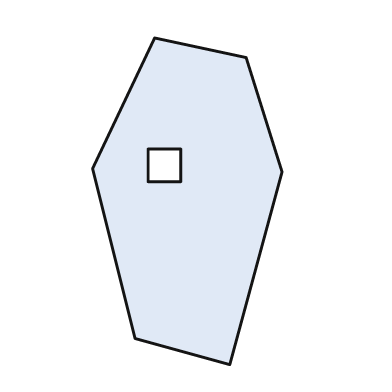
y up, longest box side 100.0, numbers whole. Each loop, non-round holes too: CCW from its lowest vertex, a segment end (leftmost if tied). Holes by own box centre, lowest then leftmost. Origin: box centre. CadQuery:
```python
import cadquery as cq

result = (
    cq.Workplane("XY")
    .moveTo(13.0, -50.0)
    .lineTo(29.0, 9.0)
    .lineTo(18.0, 44.0)
    .lineTo(-10.0, 50.0)
    .lineTo(-29.0, 10.0)
    .lineTo(-16.0, -42.0)
    .close()
    .moveTo(-12.0, 6.0)
    .lineTo(-2.0, 6.0)
    .lineTo(-2.0, 16.0)
    .lineTo(-12.0, 16.0)
    .close()
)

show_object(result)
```